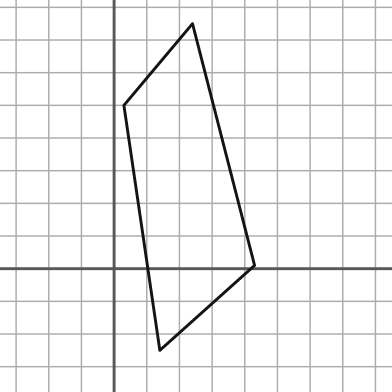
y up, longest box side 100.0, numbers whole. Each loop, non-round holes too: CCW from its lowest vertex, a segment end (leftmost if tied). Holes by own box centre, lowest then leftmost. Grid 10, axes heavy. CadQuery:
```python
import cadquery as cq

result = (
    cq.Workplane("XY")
    .moveTo(14.0, -25.0)
    .lineTo(43.0, 1.0)
    .lineTo(24.0, 75.0)
    .lineTo(3.0, 50.0)
    .close()
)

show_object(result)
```